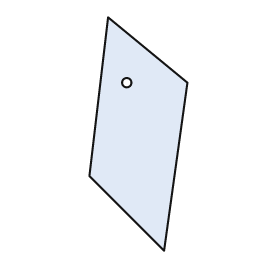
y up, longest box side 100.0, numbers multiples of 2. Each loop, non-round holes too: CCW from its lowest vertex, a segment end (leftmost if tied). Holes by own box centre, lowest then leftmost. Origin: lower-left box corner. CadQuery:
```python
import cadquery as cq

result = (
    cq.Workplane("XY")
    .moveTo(32.0, 0.0)
    .lineTo(42.0, 72.0)
    .lineTo(8.0, 100.0)
    .lineTo(0.0, 32.0)
    .close()
    .moveTo(16.0, 72.0)
    .circle(2.0)
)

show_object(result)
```